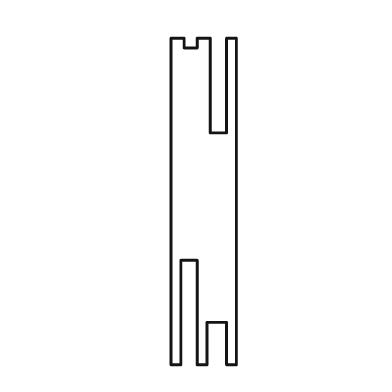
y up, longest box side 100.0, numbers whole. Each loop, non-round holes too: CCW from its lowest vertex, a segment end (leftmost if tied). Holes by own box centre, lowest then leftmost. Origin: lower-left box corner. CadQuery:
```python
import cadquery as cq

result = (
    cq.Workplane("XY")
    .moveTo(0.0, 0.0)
    .lineTo(3.0, 0.0)
    .lineTo(3.0, 32.0)
    .lineTo(8.0, 32.0)
    .lineTo(8.0, 0.0)
    .lineTo(11.0, 0.0)
    .lineTo(11.0, 13.0)
    .lineTo(17.0, 13.0)
    .lineTo(17.0, 0.0)
    .lineTo(20.0, 0.0)
    .lineTo(20.0, 100.0)
    .lineTo(17.0, 100.0)
    .lineTo(17.0, 71.0)
    .lineTo(12.0, 71.0)
    .lineTo(12.0, 100.0)
    .lineTo(8.0, 100.0)
    .lineTo(8.0, 97.0)
    .lineTo(4.0, 97.0)
    .lineTo(4.0, 100.0)
    .lineTo(0.0, 100.0)
    .close()
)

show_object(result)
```